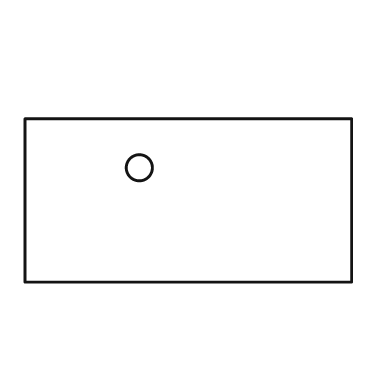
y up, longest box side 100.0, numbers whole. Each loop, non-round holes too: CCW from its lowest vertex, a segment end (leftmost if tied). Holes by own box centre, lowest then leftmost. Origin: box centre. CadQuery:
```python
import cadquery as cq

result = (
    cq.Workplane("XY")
    .moveTo(-50.0, -25.0)
    .lineTo(50.0, -25.0)
    .lineTo(50.0, 25.0)
    .lineTo(-50.0, 25.0)
    .close()
    .moveTo(-15.0, 10.0)
    .circle(4.0)
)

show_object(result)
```